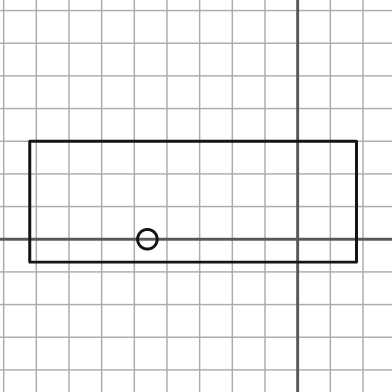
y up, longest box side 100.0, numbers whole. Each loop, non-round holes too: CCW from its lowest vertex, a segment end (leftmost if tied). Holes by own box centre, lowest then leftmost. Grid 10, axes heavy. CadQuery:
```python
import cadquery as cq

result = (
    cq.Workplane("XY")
    .moveTo(-82.0, -7.0)
    .lineTo(18.0, -7.0)
    .lineTo(18.0, 30.0)
    .lineTo(-82.0, 30.0)
    .close()
    .moveTo(-46.0, 0.0)
    .circle(3.0)
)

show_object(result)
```